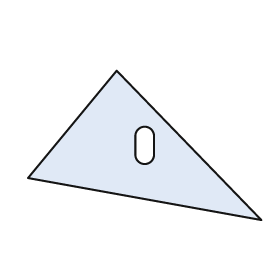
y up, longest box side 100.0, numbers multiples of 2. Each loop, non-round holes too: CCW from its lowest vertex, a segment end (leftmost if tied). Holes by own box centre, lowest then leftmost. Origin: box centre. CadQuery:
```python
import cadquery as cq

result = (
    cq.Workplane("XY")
    .moveTo(50.0, -32.0)
    .lineTo(-12.0, 32.0)
    .lineTo(-50.0, -14.0)
    .close()
    .moveTo(-4.0, -4.0)
    .threePointArc((0.0, -8.0), (4.0, -4.0))
    .lineTo(4.0, 4.0)
    .threePointArc((0.0, 8.0), (-4.0, 4.0))
    .close()
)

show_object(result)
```